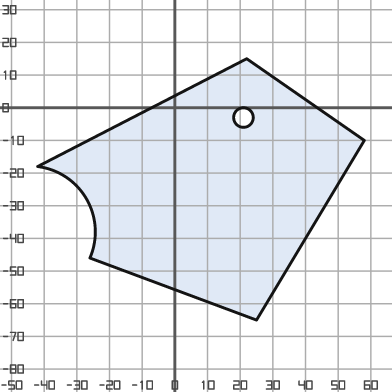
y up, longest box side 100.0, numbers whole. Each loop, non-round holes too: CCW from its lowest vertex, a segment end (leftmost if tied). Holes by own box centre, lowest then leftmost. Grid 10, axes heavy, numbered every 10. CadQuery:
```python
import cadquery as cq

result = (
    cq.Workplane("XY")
    .moveTo(25.0, -65.0)
    .lineTo(58.0, -10.0)
    .lineTo(22.0, 15.0)
    .lineTo(-42.0, -18.0)
    .threePointArc((-27.0, -28.0), (-26.0, -46.0))
    .close()
    .moveTo(21.0, -3.0)
    .circle(3.0)
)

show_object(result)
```